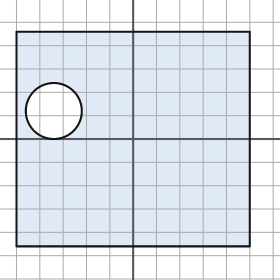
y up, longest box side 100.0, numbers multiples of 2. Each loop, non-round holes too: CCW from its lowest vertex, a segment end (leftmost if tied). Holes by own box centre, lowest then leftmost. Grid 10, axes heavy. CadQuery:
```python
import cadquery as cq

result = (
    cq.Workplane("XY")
    .moveTo(-50.0, -46.0)
    .lineTo(50.0, -46.0)
    .lineTo(50.0, 46.0)
    .lineTo(-50.0, 46.0)
    .close()
    .moveTo(-34.0, 12.0)
    .circle(12.0)
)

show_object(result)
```